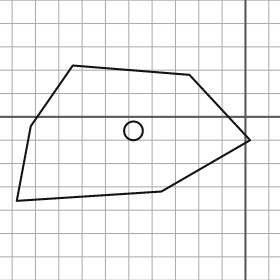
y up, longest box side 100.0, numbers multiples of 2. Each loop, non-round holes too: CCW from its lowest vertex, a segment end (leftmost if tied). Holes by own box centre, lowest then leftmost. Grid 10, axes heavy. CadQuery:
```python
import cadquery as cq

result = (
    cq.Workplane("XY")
    .moveTo(-98.0, -36.0)
    .lineTo(-36.0, -32.0)
    .lineTo(2.0, -10.0)
    .lineTo(-24.0, 18.0)
    .lineTo(-74.0, 22.0)
    .lineTo(-92.0, -4.0)
    .close()
    .moveTo(-48.0, -6.0)
    .circle(4.0)
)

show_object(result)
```